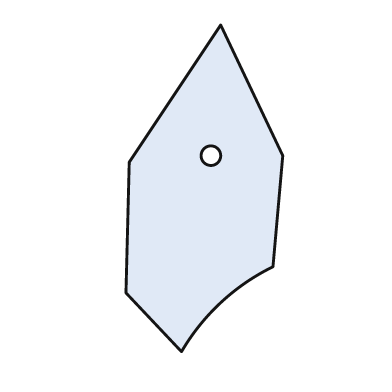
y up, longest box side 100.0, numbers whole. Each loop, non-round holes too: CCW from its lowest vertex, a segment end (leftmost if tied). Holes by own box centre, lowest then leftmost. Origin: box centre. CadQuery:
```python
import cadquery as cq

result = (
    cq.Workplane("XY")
    .moveTo(-7.0, -50.0)
    .threePointArc((5.0, -35.0), (21.0, -24.0))
    .lineTo(24.0, 10.0)
    .lineTo(5.0, 50.0)
    .lineTo(-23.0, 8.0)
    .lineTo(-24.0, -32.0)
    .close()
    .moveTo(2.0, 10.0)
    .circle(3.0)
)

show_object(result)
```